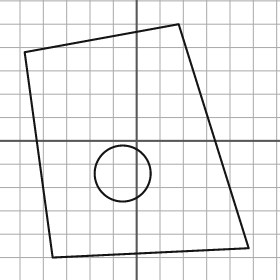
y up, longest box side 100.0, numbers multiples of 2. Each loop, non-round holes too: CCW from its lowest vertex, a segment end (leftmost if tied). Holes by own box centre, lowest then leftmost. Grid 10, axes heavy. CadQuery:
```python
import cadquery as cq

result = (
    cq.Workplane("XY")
    .moveTo(-36.0, -50.0)
    .lineTo(48.0, -46.0)
    .lineTo(18.0, 50.0)
    .lineTo(-48.0, 38.0)
    .close()
    .moveTo(-6.0, -14.0)
    .circle(12.0)
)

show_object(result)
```